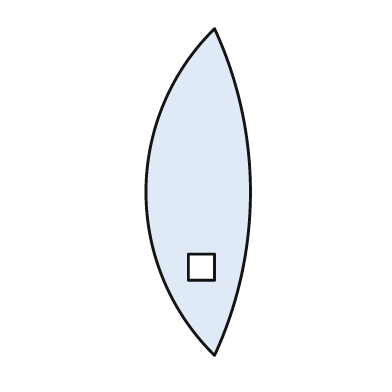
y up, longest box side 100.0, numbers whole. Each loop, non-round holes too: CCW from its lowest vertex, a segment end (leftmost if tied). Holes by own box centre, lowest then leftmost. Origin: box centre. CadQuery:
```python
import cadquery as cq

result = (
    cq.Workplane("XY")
    .moveTo(5.0, -50.0)
    .threePointArc((16.0, 0.0), (5.0, 50.0))
    .threePointArc((-16.0, 0.0), (5.0, -50.0))
    .close()
    .moveTo(-3.0, -27.0)
    .lineTo(5.0, -27.0)
    .lineTo(5.0, -19.0)
    .lineTo(-3.0, -19.0)
    .close()
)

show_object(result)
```